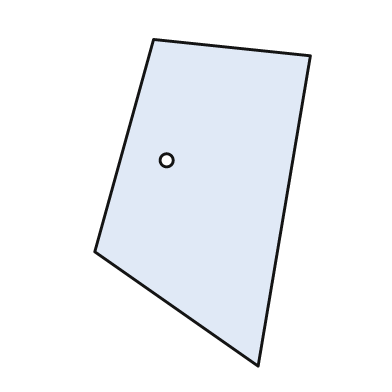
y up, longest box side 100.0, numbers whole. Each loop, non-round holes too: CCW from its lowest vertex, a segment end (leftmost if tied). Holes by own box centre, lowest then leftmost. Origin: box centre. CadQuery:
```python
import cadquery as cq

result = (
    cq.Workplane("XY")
    .moveTo(17.0, -50.0)
    .lineTo(33.0, 45.0)
    .lineTo(-15.0, 50.0)
    .lineTo(-33.0, -15.0)
    .close()
    .moveTo(-11.0, 13.0)
    .circle(2.0)
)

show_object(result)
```